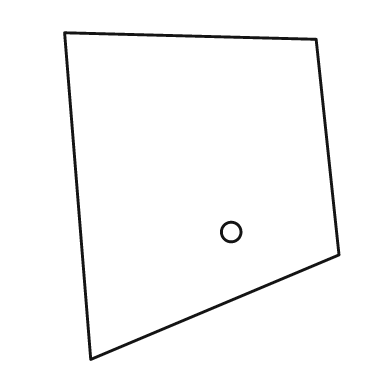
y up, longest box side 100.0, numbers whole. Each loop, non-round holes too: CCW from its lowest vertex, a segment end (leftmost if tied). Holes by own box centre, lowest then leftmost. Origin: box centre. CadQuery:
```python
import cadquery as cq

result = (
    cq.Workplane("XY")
    .moveTo(-34.0, -50.0)
    .lineTo(42.0, -18.0)
    .lineTo(35.0, 48.0)
    .lineTo(-42.0, 50.0)
    .close()
    .moveTo(9.0, -11.0)
    .circle(3.0)
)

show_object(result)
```